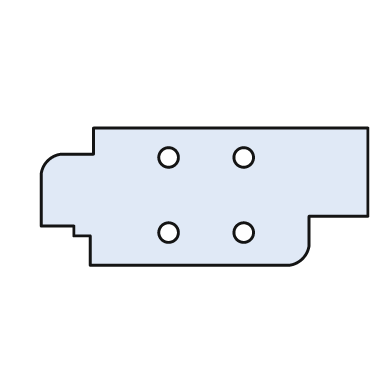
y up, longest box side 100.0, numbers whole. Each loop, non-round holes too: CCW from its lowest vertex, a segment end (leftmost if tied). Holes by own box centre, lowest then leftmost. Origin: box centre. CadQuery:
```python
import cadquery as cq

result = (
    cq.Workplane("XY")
    .moveTo(-35.0, -21.0)
    .lineTo(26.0, -21.0)
    .threePointArc((30.0, -19.0), (32.0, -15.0))
    .lineTo(32.0, -6.0)
    .lineTo(50.0, -6.0)
    .lineTo(50.0, 21.0)
    .lineTo(-34.0, 21.0)
    .lineTo(-34.0, 13.0)
    .lineTo(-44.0, 13.0)
    .threePointArc((-48.0, 11.0), (-50.0, 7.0))
    .lineTo(-50.0, -9.0)
    .lineTo(-40.0, -9.0)
    .lineTo(-40.0, -12.0)
    .lineTo(-35.0, -12.0)
    .close()
    .moveTo(-11.0, -11.0)
    .circle(3.0)
    .moveTo(12.0, -11.0)
    .circle(3.0)
    .moveTo(-11.0, 12.0)
    .circle(3.0)
    .moveTo(12.0, 12.0)
    .circle(3.0)
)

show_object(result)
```